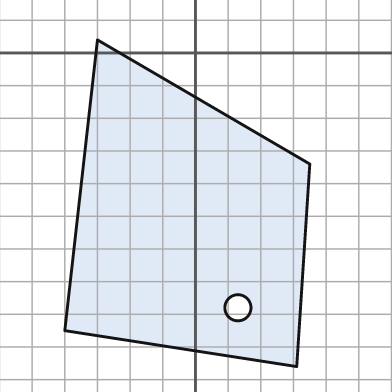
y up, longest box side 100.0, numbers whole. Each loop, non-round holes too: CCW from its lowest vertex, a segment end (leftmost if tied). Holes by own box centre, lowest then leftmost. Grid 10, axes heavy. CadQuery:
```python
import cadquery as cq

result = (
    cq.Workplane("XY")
    .moveTo(31.0, -96.0)
    .lineTo(35.0, -34.0)
    .lineTo(-30.0, 4.0)
    .lineTo(-40.0, -85.0)
    .close()
    .moveTo(13.0, -78.0)
    .circle(4.0)
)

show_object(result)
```